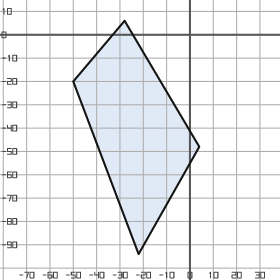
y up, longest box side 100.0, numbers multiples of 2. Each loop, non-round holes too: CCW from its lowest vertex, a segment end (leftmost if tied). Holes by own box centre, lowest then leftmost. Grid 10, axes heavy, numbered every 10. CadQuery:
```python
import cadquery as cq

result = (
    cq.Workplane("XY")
    .moveTo(-22.0, -94.0)
    .lineTo(4.0, -48.0)
    .lineTo(-28.0, 6.0)
    .lineTo(-50.0, -20.0)
    .close()
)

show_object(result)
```